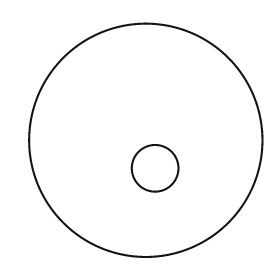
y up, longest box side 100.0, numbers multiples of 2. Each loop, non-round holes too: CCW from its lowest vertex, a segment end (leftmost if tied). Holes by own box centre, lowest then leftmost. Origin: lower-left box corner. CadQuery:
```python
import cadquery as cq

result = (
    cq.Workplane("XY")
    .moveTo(50.0, 50.0)
    .circle(50.0)
    .moveTo(54.0, 38.0)
    .circle(10.0)
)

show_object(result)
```